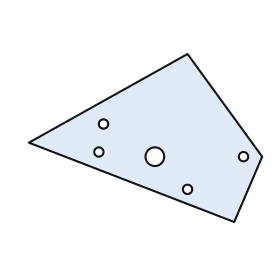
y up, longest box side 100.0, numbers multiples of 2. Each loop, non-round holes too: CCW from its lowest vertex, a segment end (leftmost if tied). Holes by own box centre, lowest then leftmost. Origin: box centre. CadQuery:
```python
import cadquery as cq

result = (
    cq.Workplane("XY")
    .moveTo(38.0, -36.0)
    .lineTo(50.0, -8.0)
    .lineTo(18.0, 36.0)
    .lineTo(-50.0, -2.0)
    .close()
    .moveTo(18.0, -22.0)
    .circle(2.0)
    .moveTo(4.0, -8.0)
    .circle(4.0)
    .moveTo(42.0, -8.0)
    .circle(2.0)
    .moveTo(-20.0, -6.0)
    .circle(2.0)
    .moveTo(-18.0, 6.0)
    .circle(2.0)
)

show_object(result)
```